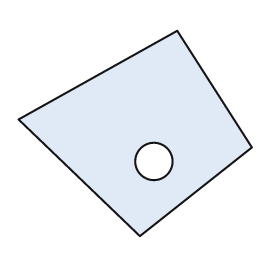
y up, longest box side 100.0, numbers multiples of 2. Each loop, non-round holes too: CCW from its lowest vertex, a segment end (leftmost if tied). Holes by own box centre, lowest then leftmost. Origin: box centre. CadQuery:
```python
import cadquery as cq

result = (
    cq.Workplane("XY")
    .moveTo(2.0, -44.0)
    .lineTo(50.0, -6.0)
    .lineTo(18.0, 44.0)
    .lineTo(-50.0, 6.0)
    .close()
    .moveTo(8.0, -12.0)
    .circle(8.0)
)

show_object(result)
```